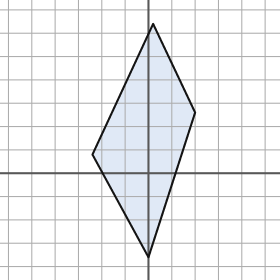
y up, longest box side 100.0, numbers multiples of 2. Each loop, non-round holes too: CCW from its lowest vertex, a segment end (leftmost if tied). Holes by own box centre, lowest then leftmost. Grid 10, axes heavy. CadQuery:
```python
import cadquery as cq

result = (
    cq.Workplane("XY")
    .moveTo(0.0, -36.0)
    .lineTo(20.0, 26.0)
    .lineTo(2.0, 64.0)
    .lineTo(-24.0, 8.0)
    .close()
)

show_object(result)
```